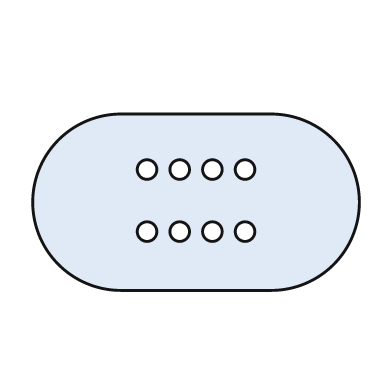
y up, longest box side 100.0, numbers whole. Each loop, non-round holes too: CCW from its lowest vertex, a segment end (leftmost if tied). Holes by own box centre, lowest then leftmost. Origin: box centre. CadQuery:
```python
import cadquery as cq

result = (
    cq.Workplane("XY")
    .moveTo(-23.0, -27.0)
    .lineTo(23.0, -27.0)
    .threePointArc((50.0, 0.0), (23.0, 27.0))
    .lineTo(-23.0, 27.0)
    .threePointArc((-50.0, 0.0), (-23.0, -27.0))
    .close()
    .moveTo(-15.0, -9.0)
    .circle(3.0)
    .moveTo(-5.0, -9.0)
    .circle(3.0)
    .moveTo(5.0, -9.0)
    .circle(3.0)
    .moveTo(15.0, -9.0)
    .circle(3.0)
    .moveTo(-15.0, 10.0)
    .circle(3.0)
    .moveTo(-5.0, 10.0)
    .circle(3.0)
    .moveTo(5.0, 10.0)
    .circle(3.0)
    .moveTo(15.0, 10.0)
    .circle(3.0)
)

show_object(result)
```